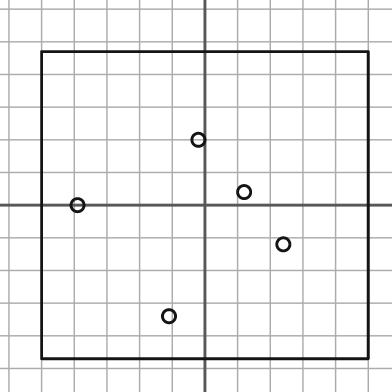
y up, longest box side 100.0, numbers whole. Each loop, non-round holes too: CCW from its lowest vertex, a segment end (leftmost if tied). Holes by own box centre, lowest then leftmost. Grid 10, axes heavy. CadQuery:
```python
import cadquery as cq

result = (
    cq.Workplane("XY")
    .moveTo(-50.0, -47.0)
    .lineTo(50.0, -47.0)
    .lineTo(50.0, 47.0)
    .lineTo(-50.0, 47.0)
    .close()
    .moveTo(-11.0, -34.0)
    .circle(2.0)
    .moveTo(24.0, -12.0)
    .circle(2.0)
    .moveTo(-39.0, 0.0)
    .circle(2.0)
    .moveTo(12.0, 4.0)
    .circle(2.0)
    .moveTo(-2.0, 20.0)
    .circle(2.0)
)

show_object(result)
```